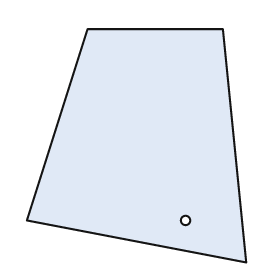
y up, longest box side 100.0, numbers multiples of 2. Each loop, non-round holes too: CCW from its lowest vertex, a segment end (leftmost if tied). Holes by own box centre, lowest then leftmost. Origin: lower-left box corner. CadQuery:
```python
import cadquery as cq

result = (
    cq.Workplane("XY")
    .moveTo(94.0, 0.0)
    .lineTo(84.0, 100.0)
    .lineTo(26.0, 100.0)
    .lineTo(0.0, 18.0)
    .close()
    .moveTo(68.0, 18.0)
    .circle(2.0)
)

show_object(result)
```